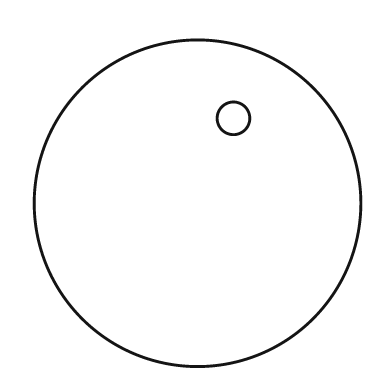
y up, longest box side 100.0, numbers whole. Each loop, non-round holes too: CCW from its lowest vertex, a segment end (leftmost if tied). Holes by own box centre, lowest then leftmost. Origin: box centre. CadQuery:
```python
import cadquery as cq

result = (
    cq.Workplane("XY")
    .moveTo(0.0, 0.0)
    .circle(50.0)
    .moveTo(11.0, 26.0)
    .circle(5.0)
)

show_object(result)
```